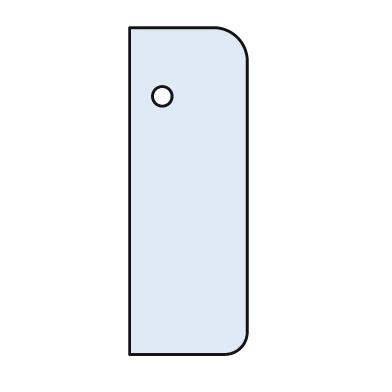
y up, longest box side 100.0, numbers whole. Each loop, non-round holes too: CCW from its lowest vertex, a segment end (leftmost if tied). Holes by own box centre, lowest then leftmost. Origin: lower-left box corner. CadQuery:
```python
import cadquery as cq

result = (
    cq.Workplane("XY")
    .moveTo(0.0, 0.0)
    .lineTo(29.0, 0.0)
    .threePointArc((34.0, 2.0), (36.0, 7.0))
    .lineTo(36.0, 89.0)
    .threePointArc((33.0, 97.0), (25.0, 100.0))
    .lineTo(0.0, 100.0)
    .close()
    .moveTo(10.0, 79.0)
    .circle(3.0)
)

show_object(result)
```